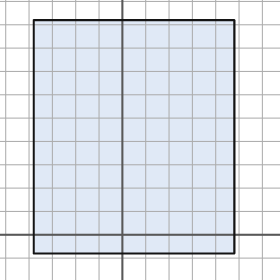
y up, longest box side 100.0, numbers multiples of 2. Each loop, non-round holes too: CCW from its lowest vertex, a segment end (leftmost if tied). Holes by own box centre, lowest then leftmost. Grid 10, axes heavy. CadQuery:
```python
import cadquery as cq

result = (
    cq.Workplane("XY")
    .moveTo(-38.0, -8.0)
    .lineTo(48.0, -8.0)
    .lineTo(48.0, 92.0)
    .lineTo(-38.0, 92.0)
    .close()
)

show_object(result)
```